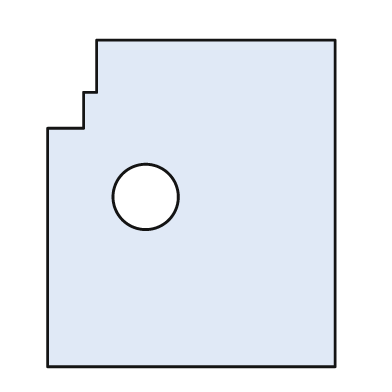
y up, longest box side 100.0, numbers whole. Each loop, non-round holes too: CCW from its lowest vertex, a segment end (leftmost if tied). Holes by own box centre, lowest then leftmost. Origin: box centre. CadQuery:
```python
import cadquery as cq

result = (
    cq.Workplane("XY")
    .moveTo(-44.0, -50.0)
    .lineTo(44.0, -50.0)
    .lineTo(44.0, 50.0)
    .lineTo(-29.0, 50.0)
    .lineTo(-29.0, 34.0)
    .lineTo(-33.0, 34.0)
    .lineTo(-33.0, 23.0)
    .lineTo(-44.0, 23.0)
    .close()
    .moveTo(-14.0, 2.0)
    .circle(10.0)
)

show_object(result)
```